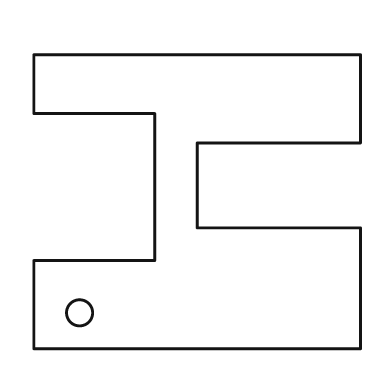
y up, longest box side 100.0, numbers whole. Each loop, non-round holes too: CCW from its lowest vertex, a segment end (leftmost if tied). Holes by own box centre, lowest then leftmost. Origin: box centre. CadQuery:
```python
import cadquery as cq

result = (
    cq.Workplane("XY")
    .moveTo(-50.0, -45.0)
    .lineTo(50.0, -45.0)
    .lineTo(50.0, -8.0)
    .lineTo(0.0, -8.0)
    .lineTo(0.0, 18.0)
    .lineTo(50.0, 18.0)
    .lineTo(50.0, 45.0)
    .lineTo(-50.0, 45.0)
    .lineTo(-50.0, 27.0)
    .lineTo(-13.0, 27.0)
    .lineTo(-13.0, -18.0)
    .lineTo(-50.0, -18.0)
    .close()
    .moveTo(-36.0, -34.0)
    .circle(4.0)
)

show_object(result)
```